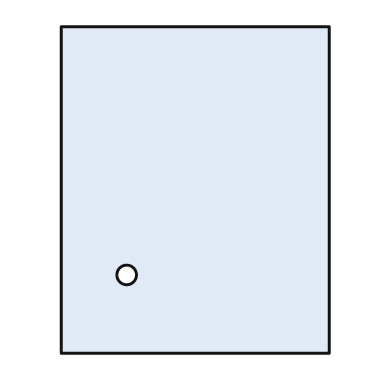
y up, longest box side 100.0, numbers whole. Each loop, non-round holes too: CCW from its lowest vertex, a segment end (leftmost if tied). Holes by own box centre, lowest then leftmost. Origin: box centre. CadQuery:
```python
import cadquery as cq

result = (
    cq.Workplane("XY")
    .moveTo(-41.0, -50.0)
    .lineTo(41.0, -50.0)
    .lineTo(41.0, 50.0)
    .lineTo(-41.0, 50.0)
    .close()
    .moveTo(-21.0, -26.0)
    .circle(3.0)
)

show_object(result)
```